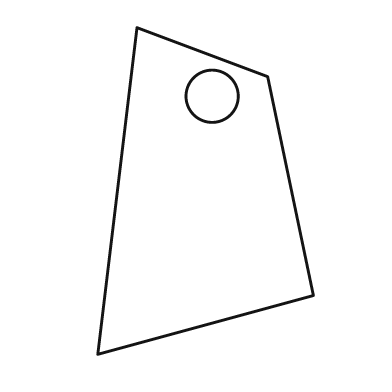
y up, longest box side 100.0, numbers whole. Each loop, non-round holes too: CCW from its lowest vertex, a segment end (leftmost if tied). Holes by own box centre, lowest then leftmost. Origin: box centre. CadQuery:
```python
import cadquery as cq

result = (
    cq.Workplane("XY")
    .moveTo(-33.0, -50.0)
    .lineTo(33.0, -32.0)
    .lineTo(19.0, 35.0)
    .lineTo(-21.0, 50.0)
    .close()
    .moveTo(2.0, 29.0)
    .circle(8.0)
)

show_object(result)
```